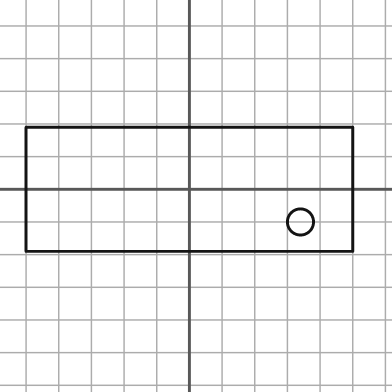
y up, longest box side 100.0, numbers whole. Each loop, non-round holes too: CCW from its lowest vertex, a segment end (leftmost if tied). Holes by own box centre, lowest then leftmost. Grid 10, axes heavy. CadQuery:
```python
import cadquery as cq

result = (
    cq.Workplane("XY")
    .moveTo(-50.0, -19.0)
    .lineTo(50.0, -19.0)
    .lineTo(50.0, 19.0)
    .lineTo(-50.0, 19.0)
    .close()
    .moveTo(34.0, -10.0)
    .circle(4.0)
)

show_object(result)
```